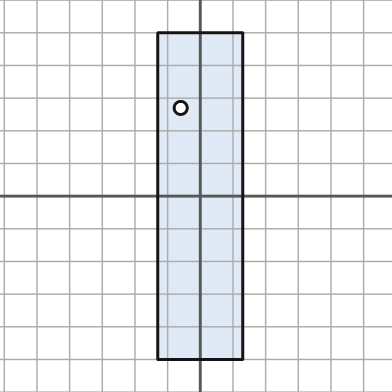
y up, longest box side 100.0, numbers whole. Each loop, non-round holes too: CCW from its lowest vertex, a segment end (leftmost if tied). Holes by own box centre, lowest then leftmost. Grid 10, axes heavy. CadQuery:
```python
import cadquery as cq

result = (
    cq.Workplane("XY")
    .moveTo(-13.0, -50.0)
    .lineTo(13.0, -50.0)
    .lineTo(13.0, 50.0)
    .lineTo(-13.0, 50.0)
    .close()
    .moveTo(-6.0, 27.0)
    .circle(2.0)
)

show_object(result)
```